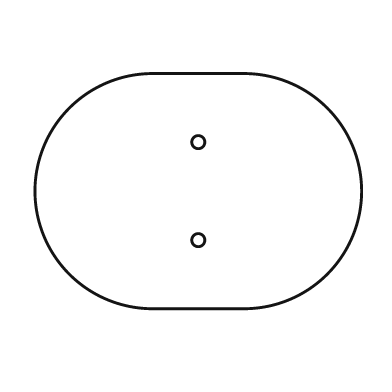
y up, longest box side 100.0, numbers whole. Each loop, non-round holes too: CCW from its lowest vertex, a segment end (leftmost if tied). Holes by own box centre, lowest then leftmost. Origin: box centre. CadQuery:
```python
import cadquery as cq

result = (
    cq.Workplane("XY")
    .moveTo(-14.0, -36.0)
    .lineTo(14.0, -36.0)
    .threePointArc((50.0, 0.0), (14.0, 36.0))
    .lineTo(-14.0, 36.0)
    .threePointArc((-50.0, 0.0), (-14.0, -36.0))
    .close()
    .moveTo(0.0, -15.0)
    .circle(2.0)
    .moveTo(0.0, 15.0)
    .circle(2.0)
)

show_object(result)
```